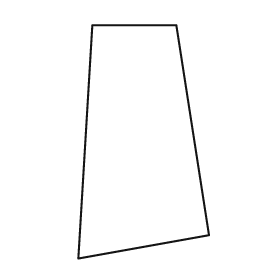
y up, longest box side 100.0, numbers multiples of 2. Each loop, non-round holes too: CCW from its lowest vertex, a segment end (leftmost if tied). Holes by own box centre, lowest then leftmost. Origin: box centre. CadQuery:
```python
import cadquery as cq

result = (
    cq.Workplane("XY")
    .moveTo(-28.0, -50.0)
    .lineTo(28.0, -40.0)
    .lineTo(14.0, 50.0)
    .lineTo(-22.0, 50.0)
    .close()
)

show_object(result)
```